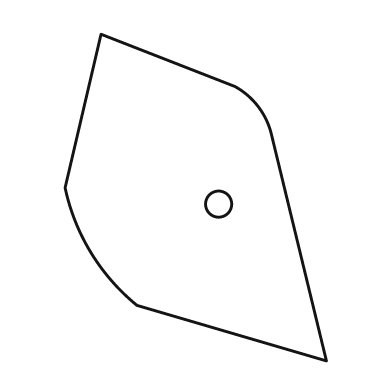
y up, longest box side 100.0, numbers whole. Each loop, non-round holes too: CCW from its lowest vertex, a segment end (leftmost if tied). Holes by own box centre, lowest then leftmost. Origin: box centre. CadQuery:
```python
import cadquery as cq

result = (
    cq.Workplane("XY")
    .moveTo(40.0, -50.0)
    .lineTo(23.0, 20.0)
    .threePointArc((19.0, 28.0), (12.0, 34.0))
    .lineTo(-29.0, 50.0)
    .lineTo(-40.0, 3.0)
    .threePointArc((-32.0, -17.0), (-18.0, -33.0))
    .close()
    .moveTo(7.0, -2.0)
    .circle(4.0)
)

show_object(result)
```